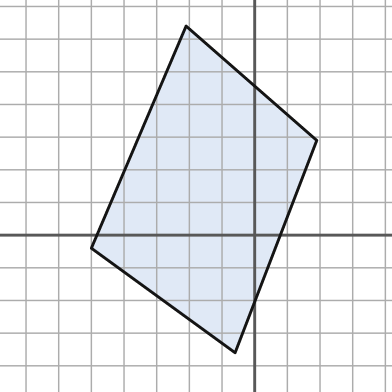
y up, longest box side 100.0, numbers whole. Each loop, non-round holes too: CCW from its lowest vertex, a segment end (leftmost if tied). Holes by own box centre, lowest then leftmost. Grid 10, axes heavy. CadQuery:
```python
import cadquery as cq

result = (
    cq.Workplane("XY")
    .moveTo(-6.0, -36.0)
    .lineTo(19.0, 29.0)
    .lineTo(-21.0, 64.0)
    .lineTo(-50.0, -4.0)
    .close()
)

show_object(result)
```